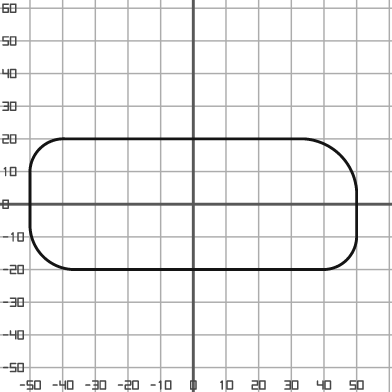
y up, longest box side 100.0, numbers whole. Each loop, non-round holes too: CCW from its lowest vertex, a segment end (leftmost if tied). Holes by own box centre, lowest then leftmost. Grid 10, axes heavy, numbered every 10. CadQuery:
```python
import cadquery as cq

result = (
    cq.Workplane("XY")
    .moveTo(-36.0, -20.0)
    .lineTo(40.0, -20.0)
    .threePointArc((47.0, -17.0), (50.0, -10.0))
    .lineTo(50.0, 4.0)
    .threePointArc((45.0, 15.0), (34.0, 20.0))
    .lineTo(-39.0, 20.0)
    .threePointArc((-47.0, 17.0), (-50.0, 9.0))
    .lineTo(-50.0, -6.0)
    .threePointArc((-46.0, -16.0), (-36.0, -20.0))
    .close()
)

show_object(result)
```